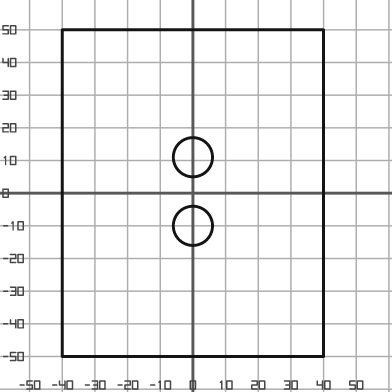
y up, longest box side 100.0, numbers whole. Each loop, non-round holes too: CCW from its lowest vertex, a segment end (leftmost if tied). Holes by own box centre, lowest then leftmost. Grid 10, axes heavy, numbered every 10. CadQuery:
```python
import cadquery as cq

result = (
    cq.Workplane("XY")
    .moveTo(-40.0, -50.0)
    .lineTo(40.0, -50.0)
    .lineTo(40.0, 50.0)
    .lineTo(-40.0, 50.0)
    .close()
    .moveTo(0.0, -10.0)
    .circle(6.0)
    .moveTo(0.0, 11.0)
    .circle(6.0)
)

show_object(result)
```